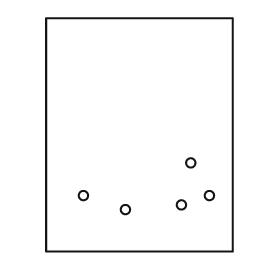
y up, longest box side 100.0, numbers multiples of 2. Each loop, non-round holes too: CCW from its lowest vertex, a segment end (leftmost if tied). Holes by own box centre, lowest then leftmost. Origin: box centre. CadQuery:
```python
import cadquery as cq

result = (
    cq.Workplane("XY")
    .moveTo(-40.0, -50.0)
    .lineTo(40.0, -50.0)
    .lineTo(40.0, 50.0)
    .lineTo(-40.0, 50.0)
    .close()
    .moveTo(-6.0, -32.0)
    .circle(2.0)
    .moveTo(18.0, -30.0)
    .circle(2.0)
    .moveTo(-24.0, -26.0)
    .circle(2.0)
    .moveTo(30.0, -26.0)
    .circle(2.0)
    .moveTo(22.0, -12.0)
    .circle(2.0)
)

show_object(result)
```